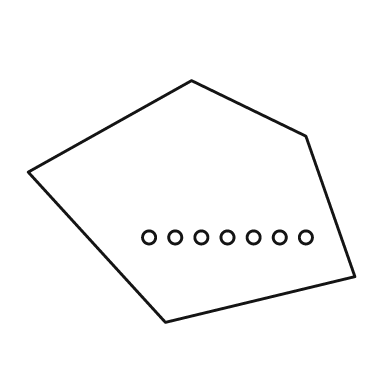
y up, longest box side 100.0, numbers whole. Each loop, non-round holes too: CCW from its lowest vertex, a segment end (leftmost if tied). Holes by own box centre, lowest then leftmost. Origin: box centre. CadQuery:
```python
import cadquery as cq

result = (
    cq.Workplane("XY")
    .moveTo(-8.0, -37.0)
    .lineTo(50.0, -23.0)
    .lineTo(35.0, 20.0)
    .lineTo(0.0, 37.0)
    .lineTo(-50.0, 9.0)
    .close()
    .moveTo(-13.0, -11.0)
    .circle(2.0)
    .moveTo(-5.0, -11.0)
    .circle(2.0)
    .moveTo(3.0, -11.0)
    .circle(2.0)
    .moveTo(11.0, -11.0)
    .circle(2.0)
    .moveTo(19.0, -11.0)
    .circle(2.0)
    .moveTo(27.0, -11.0)
    .circle(2.0)
    .moveTo(35.0, -11.0)
    .circle(2.0)
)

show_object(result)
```